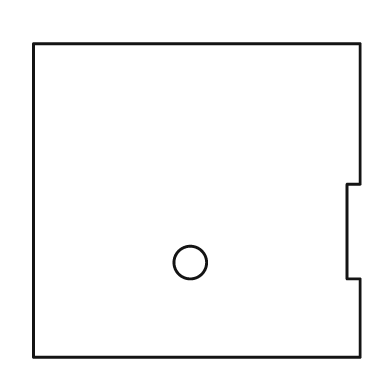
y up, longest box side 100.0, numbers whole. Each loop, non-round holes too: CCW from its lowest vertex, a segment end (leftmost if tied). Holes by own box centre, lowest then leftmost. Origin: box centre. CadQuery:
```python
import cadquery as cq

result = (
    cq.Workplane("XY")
    .moveTo(-50.0, -48.0)
    .lineTo(50.0, -48.0)
    .lineTo(50.0, -24.0)
    .lineTo(46.0, -24.0)
    .lineTo(46.0, 5.0)
    .lineTo(50.0, 5.0)
    .lineTo(50.0, 48.0)
    .lineTo(-50.0, 48.0)
    .close()
    .moveTo(-2.0, -19.0)
    .circle(5.0)
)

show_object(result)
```